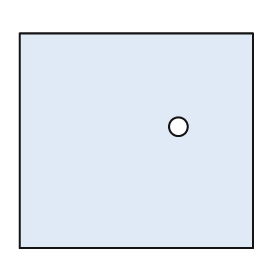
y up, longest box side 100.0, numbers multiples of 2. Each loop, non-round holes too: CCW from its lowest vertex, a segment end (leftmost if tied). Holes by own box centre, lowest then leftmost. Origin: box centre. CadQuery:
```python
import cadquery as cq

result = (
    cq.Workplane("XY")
    .moveTo(-50.0, -46.0)
    .lineTo(50.0, -46.0)
    .lineTo(50.0, 46.0)
    .lineTo(-50.0, 46.0)
    .close()
    .moveTo(18.0, 6.0)
    .circle(4.0)
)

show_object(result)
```